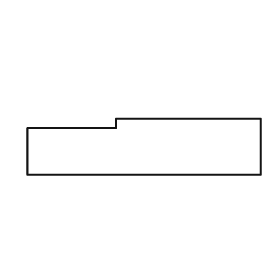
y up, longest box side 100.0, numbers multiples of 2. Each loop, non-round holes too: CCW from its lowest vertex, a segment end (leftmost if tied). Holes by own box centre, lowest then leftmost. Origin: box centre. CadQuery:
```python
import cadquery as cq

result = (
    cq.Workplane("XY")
    .moveTo(-50.0, -12.0)
    .lineTo(50.0, -12.0)
    .lineTo(50.0, 12.0)
    .lineTo(-12.0, 12.0)
    .lineTo(-12.0, 8.0)
    .lineTo(-50.0, 8.0)
    .close()
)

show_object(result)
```